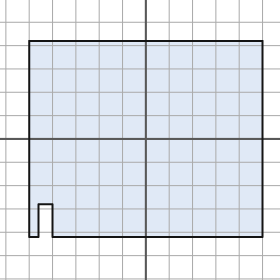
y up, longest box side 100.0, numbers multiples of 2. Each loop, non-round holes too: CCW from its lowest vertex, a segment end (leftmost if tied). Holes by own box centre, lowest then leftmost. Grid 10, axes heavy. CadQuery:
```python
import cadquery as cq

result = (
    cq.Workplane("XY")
    .moveTo(-50.0, -42.0)
    .lineTo(-46.0, -42.0)
    .lineTo(-46.0, -28.0)
    .lineTo(-40.0, -28.0)
    .lineTo(-40.0, -42.0)
    .lineTo(50.0, -42.0)
    .lineTo(50.0, 42.0)
    .lineTo(-50.0, 42.0)
    .close()
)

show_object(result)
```